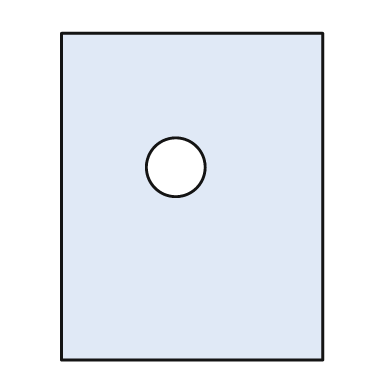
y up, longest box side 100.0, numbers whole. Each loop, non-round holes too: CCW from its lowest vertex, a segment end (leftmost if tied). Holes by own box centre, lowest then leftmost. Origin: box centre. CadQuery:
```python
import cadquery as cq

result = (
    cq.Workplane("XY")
    .moveTo(-40.0, -50.0)
    .lineTo(40.0, -50.0)
    .lineTo(40.0, 50.0)
    .lineTo(-40.0, 50.0)
    .close()
    .moveTo(-5.0, 9.0)
    .circle(9.0)
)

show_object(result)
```